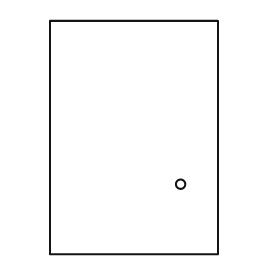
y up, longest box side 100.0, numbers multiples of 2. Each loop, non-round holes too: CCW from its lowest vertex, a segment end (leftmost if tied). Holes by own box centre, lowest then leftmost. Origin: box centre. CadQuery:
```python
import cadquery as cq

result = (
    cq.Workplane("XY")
    .moveTo(-36.0, -50.0)
    .lineTo(36.0, -50.0)
    .lineTo(36.0, 50.0)
    .lineTo(-36.0, 50.0)
    .close()
    .moveTo(20.0, -20.0)
    .circle(2.0)
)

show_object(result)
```